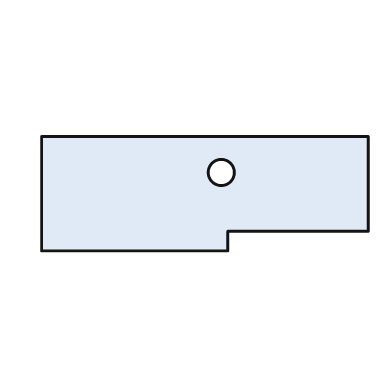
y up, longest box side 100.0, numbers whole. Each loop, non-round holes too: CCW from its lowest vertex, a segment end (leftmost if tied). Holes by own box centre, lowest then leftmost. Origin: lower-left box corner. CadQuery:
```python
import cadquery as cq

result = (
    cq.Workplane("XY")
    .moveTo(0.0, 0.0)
    .lineTo(57.0, 0.0)
    .lineTo(57.0, 6.0)
    .lineTo(100.0, 6.0)
    .lineTo(100.0, 35.0)
    .lineTo(0.0, 35.0)
    .close()
    .moveTo(55.0, 24.0)
    .circle(4.0)
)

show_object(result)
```